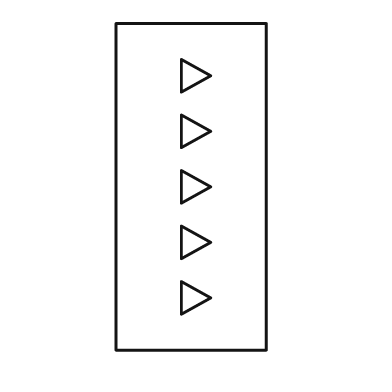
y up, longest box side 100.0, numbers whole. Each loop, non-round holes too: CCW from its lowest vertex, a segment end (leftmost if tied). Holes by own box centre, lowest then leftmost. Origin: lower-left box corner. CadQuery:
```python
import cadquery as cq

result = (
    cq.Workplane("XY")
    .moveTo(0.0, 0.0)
    .lineTo(46.0, 0.0)
    .lineTo(46.0, 100.0)
    .lineTo(0.0, 100.0)
    .close()
    .moveTo(20.0, 11.0)
    .lineTo(29.0, 16.0)
    .lineTo(20.0, 21.0)
    .close()
    .moveTo(20.0, 28.0)
    .lineTo(29.0, 33.0)
    .lineTo(20.0, 38.0)
    .close()
    .moveTo(20.0, 45.0)
    .lineTo(29.0, 50.0)
    .lineTo(20.0, 55.0)
    .close()
    .moveTo(20.0, 62.0)
    .lineTo(29.0, 67.0)
    .lineTo(20.0, 72.0)
    .close()
    .moveTo(20.0, 79.0)
    .lineTo(29.0, 84.0)
    .lineTo(20.0, 89.0)
    .close()
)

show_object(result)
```